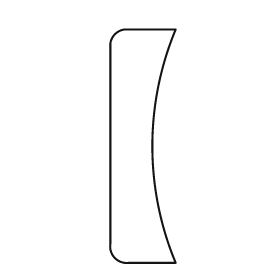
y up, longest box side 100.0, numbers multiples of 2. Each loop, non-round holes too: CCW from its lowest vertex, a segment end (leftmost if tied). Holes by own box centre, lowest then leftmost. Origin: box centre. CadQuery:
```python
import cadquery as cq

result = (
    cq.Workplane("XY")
    .moveTo(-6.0, -50.0)
    .lineTo(14.0, -50.0)
    .threePointArc((4.0, 0.0), (14.0, 50.0))
    .lineTo(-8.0, 50.0)
    .threePointArc((-12.0, 48.0), (-14.0, 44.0))
    .lineTo(-14.0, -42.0)
    .threePointArc((-12.0, -48.0), (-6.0, -50.0))
    .close()
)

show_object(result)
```